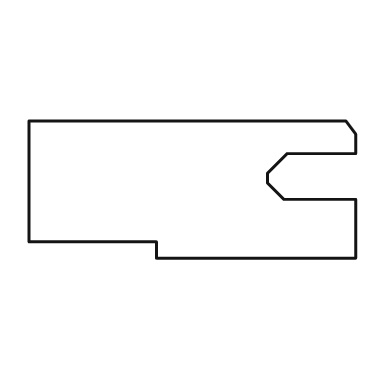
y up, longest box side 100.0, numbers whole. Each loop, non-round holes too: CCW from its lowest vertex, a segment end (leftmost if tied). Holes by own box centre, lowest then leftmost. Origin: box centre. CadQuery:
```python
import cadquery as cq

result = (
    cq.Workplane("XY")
    .moveTo(-11.0, -21.0)
    .lineTo(50.0, -21.0)
    .lineTo(50.0, -3.0)
    .lineTo(28.0, -3.0)
    .lineTo(23.0, 2.0)
    .lineTo(23.0, 5.0)
    .lineTo(29.0, 11.0)
    .lineTo(50.0, 11.0)
    .lineTo(50.0, 17.0)
    .lineTo(47.0, 21.0)
    .lineTo(-50.0, 21.0)
    .lineTo(-50.0, -16.0)
    .lineTo(-11.0, -16.0)
    .close()
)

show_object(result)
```